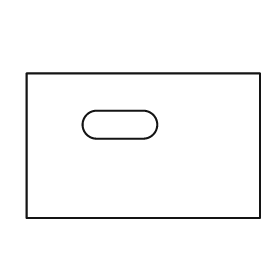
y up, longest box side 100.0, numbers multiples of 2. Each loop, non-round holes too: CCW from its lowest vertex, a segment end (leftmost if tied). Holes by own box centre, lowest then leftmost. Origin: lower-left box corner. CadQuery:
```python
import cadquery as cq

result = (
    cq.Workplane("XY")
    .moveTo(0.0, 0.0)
    .lineTo(100.0, 0.0)
    .lineTo(100.0, 62.0)
    .lineTo(0.0, 62.0)
    .close()
    .moveTo(30.0, 34.0)
    .lineTo(50.0, 34.0)
    .threePointArc((56.0, 40.0), (50.0, 46.0))
    .lineTo(30.0, 46.0)
    .threePointArc((24.0, 40.0), (30.0, 34.0))
    .close()
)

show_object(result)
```